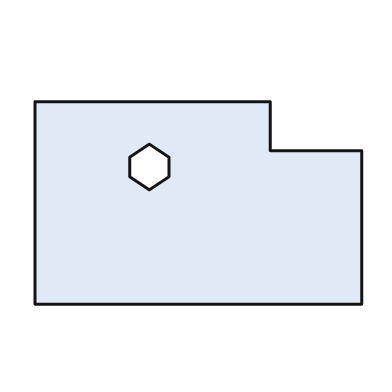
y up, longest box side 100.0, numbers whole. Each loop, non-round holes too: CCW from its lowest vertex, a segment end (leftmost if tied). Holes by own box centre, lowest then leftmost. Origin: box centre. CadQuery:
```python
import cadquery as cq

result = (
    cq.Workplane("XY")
    .moveTo(-50.0, -31.0)
    .lineTo(50.0, -31.0)
    .lineTo(50.0, 16.0)
    .lineTo(22.0, 16.0)
    .lineTo(22.0, 31.0)
    .lineTo(-50.0, 31.0)
    .close()
    .moveTo(-15.0, 4.0)
    .lineTo(-9.0, 8.0)
    .lineTo(-9.0, 14.0)
    .lineTo(-15.0, 18.0)
    .lineTo(-21.0, 14.0)
    .lineTo(-21.0, 8.0)
    .close()
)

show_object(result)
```